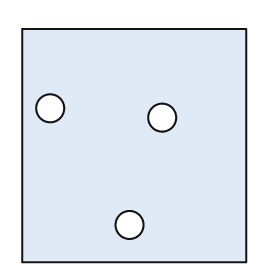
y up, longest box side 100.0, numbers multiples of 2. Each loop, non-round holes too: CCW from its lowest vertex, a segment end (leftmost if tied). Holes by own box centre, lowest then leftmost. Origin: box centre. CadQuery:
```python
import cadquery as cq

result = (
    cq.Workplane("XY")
    .moveTo(-48.0, -50.0)
    .lineTo(48.0, -50.0)
    .lineTo(48.0, 50.0)
    .lineTo(-48.0, 50.0)
    .close()
    .moveTo(-2.0, -34.0)
    .circle(6.0)
    .moveTo(12.0, 12.0)
    .circle(6.0)
    .moveTo(-36.0, 16.0)
    .circle(6.0)
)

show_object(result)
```